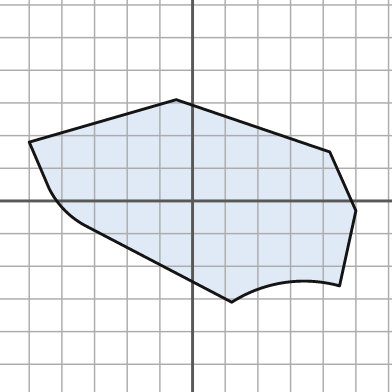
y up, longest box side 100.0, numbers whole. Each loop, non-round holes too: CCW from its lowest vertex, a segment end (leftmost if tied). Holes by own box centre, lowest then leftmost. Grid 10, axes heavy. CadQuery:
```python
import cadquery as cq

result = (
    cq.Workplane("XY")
    .moveTo(12.0, -31.0)
    .threePointArc((28.0, -25.0), (45.0, -26.0))
    .lineTo(50.0, -3.0)
    .lineTo(42.0, 15.0)
    .lineTo(-5.0, 31.0)
    .lineTo(-50.0, 18.0)
    .lineTo(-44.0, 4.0)
    .threePointArc((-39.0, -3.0), (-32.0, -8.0))
    .close()
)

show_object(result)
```